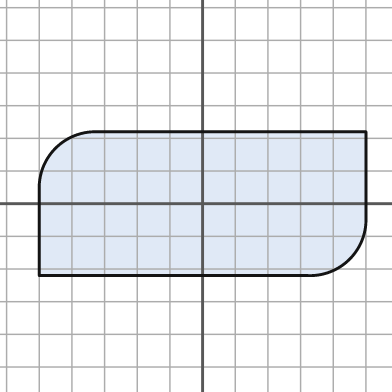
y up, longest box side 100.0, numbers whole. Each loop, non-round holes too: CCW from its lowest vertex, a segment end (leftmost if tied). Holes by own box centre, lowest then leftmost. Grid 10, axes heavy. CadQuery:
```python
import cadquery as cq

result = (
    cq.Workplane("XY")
    .moveTo(-50.0, -22.0)
    .lineTo(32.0, -22.0)
    .threePointArc((45.0, -17.0), (50.0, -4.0))
    .lineTo(50.0, 22.0)
    .lineTo(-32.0, 22.0)
    .threePointArc((-45.0, 17.0), (-50.0, 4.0))
    .close()
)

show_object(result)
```